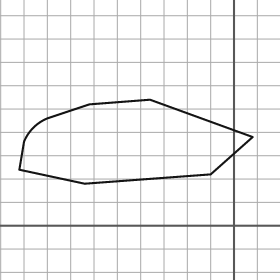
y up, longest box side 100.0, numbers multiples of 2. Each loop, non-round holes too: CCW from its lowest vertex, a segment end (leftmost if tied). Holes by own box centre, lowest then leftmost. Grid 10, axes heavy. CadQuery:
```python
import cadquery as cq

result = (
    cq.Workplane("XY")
    .moveTo(-64.0, 18.0)
    .lineTo(-10.0, 22.0)
    .lineTo(8.0, 38.0)
    .lineTo(-36.0, 54.0)
    .lineTo(-62.0, 52.0)
    .lineTo(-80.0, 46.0)
    .threePointArc((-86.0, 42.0), (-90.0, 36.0))
    .lineTo(-92.0, 24.0)
    .close()
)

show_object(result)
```